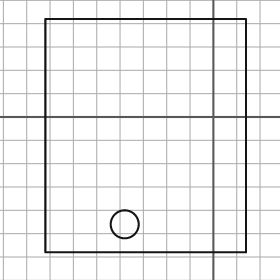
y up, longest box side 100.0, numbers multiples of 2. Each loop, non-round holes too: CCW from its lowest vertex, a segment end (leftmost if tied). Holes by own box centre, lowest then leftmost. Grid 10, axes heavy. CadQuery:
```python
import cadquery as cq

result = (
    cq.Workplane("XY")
    .moveTo(-72.0, -58.0)
    .lineTo(14.0, -58.0)
    .lineTo(14.0, 42.0)
    .lineTo(-72.0, 42.0)
    .close()
    .moveTo(-38.0, -46.0)
    .circle(6.0)
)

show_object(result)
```